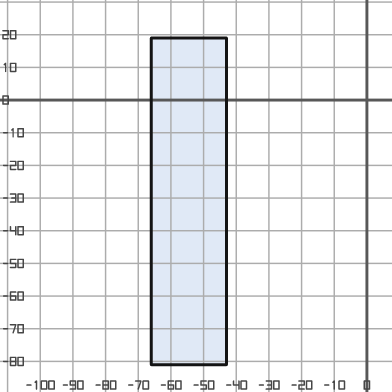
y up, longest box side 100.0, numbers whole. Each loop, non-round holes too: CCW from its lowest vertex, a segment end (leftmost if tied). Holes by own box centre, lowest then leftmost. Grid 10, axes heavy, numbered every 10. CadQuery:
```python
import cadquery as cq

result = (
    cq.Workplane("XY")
    .moveTo(-66.0, -81.0)
    .lineTo(-43.0, -81.0)
    .lineTo(-43.0, 19.0)
    .lineTo(-66.0, 19.0)
    .close()
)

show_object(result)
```